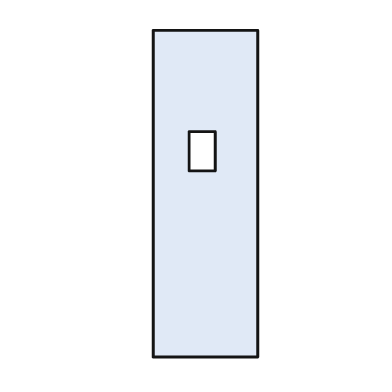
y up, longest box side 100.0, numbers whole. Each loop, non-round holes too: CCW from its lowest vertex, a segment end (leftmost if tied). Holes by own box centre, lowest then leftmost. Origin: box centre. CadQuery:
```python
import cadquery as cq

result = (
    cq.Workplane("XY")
    .moveTo(-16.0, -50.0)
    .lineTo(16.0, -50.0)
    .lineTo(16.0, 50.0)
    .lineTo(-16.0, 50.0)
    .close()
    .moveTo(-5.0, 7.0)
    .lineTo(3.0, 7.0)
    .lineTo(3.0, 19.0)
    .lineTo(-5.0, 19.0)
    .close()
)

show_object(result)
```